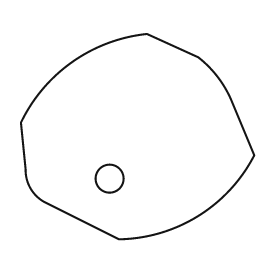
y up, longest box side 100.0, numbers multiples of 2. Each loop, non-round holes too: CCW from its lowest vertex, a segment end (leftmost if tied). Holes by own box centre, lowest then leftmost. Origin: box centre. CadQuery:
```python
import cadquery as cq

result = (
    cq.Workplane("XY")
    .moveTo(-8.0, -44.0)
    .threePointArc((26.0, -34.0), (50.0, -8.0))
    .lineTo(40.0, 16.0)
    .threePointArc((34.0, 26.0), (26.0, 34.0))
    .lineTo(4.0, 44.0)
    .threePointArc((-28.0, 32.0), (-50.0, 6.0))
    .lineTo(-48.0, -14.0)
    .threePointArc((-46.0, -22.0), (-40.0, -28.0))
    .close()
    .moveTo(-12.0, -18.0)
    .circle(6.0)
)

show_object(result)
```